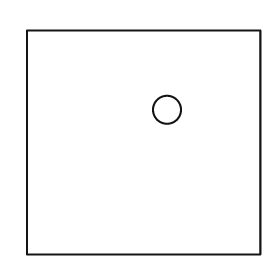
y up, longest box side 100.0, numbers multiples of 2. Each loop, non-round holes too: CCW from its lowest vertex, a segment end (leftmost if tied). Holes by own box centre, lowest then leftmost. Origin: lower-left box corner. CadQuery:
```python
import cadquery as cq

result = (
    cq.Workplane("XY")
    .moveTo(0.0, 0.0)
    .lineTo(100.0, 0.0)
    .lineTo(100.0, 96.0)
    .lineTo(0.0, 96.0)
    .close()
    .moveTo(60.0, 62.0)
    .circle(6.0)
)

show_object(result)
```